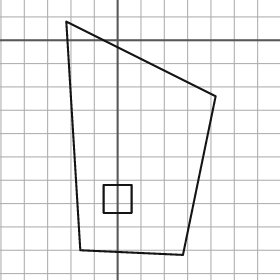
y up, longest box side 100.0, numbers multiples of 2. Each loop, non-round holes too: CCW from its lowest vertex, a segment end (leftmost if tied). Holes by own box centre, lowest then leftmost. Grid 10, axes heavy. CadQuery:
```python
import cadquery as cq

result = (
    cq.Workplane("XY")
    .moveTo(28.0, -92.0)
    .lineTo(42.0, -24.0)
    .lineTo(-22.0, 8.0)
    .lineTo(-16.0, -90.0)
    .close()
    .moveTo(-6.0, -74.0)
    .lineTo(6.0, -74.0)
    .lineTo(6.0, -62.0)
    .lineTo(-6.0, -62.0)
    .close()
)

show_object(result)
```